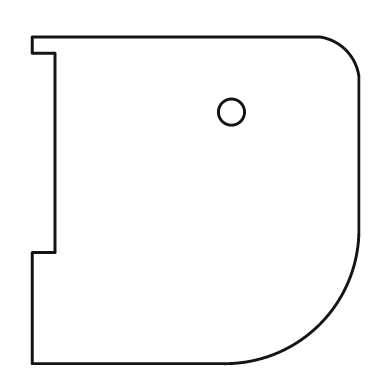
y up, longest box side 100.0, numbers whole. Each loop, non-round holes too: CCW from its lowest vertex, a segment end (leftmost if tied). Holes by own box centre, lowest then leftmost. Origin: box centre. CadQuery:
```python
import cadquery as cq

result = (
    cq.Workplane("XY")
    .moveTo(-50.0, -50.0)
    .lineTo(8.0, -50.0)
    .threePointArc((38.0, -38.0), (50.0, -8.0))
    .lineTo(50.0, 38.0)
    .threePointArc((46.0, 46.0), (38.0, 50.0))
    .lineTo(-50.0, 50.0)
    .lineTo(-50.0, 45.0)
    .lineTo(-43.0, 45.0)
    .lineTo(-43.0, -16.0)
    .lineTo(-50.0, -16.0)
    .close()
    .moveTo(11.0, 27.0)
    .circle(4.0)
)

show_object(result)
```